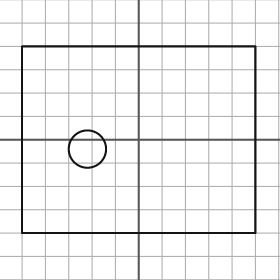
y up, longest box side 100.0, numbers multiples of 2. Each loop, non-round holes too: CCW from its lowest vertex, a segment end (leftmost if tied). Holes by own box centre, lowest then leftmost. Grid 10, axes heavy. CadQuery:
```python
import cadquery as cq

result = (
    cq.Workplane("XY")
    .moveTo(-50.0, -40.0)
    .lineTo(50.0, -40.0)
    .lineTo(50.0, 40.0)
    .lineTo(-50.0, 40.0)
    .close()
    .moveTo(-22.0, -4.0)
    .circle(8.0)
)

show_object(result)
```